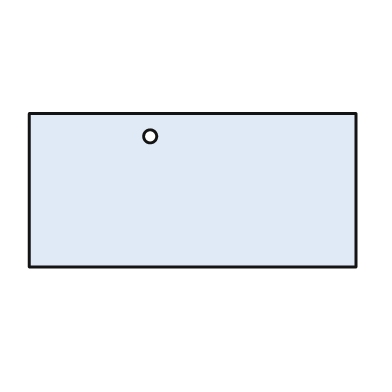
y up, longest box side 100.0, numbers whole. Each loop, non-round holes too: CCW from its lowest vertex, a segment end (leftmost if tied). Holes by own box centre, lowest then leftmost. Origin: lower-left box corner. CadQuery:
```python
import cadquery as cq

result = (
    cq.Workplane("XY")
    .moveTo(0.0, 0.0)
    .lineTo(100.0, 0.0)
    .lineTo(100.0, 47.0)
    .lineTo(0.0, 47.0)
    .close()
    .moveTo(37.0, 40.0)
    .circle(2.0)
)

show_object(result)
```